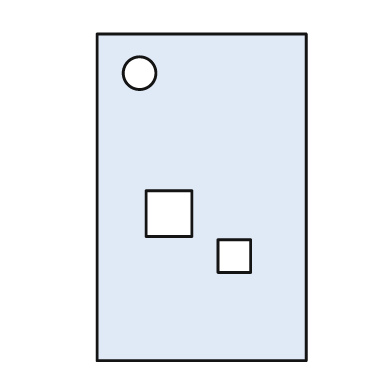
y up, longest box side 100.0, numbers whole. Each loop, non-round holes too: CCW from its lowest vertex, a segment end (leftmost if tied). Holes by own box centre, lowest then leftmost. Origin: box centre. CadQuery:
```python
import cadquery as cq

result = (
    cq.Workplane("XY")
    .moveTo(-32.0, -50.0)
    .lineTo(32.0, -50.0)
    .lineTo(32.0, 50.0)
    .lineTo(-32.0, 50.0)
    .close()
    .moveTo(5.0, -23.0)
    .lineTo(15.0, -23.0)
    .lineTo(15.0, -13.0)
    .lineTo(5.0, -13.0)
    .close()
    .moveTo(-17.0, -12.0)
    .lineTo(-3.0, -12.0)
    .lineTo(-3.0, 2.0)
    .lineTo(-17.0, 2.0)
    .close()
    .moveTo(-19.0, 38.0)
    .circle(5.0)
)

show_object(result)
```